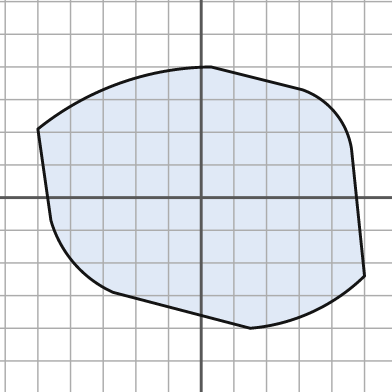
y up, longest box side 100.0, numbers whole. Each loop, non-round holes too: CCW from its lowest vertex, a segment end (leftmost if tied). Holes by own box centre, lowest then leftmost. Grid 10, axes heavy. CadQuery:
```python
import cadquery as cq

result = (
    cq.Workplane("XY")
    .moveTo(15.0, -40.0)
    .threePointArc((34.0, -35.0), (50.0, -24.0))
    .lineTo(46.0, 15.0)
    .threePointArc((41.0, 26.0), (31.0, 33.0))
    .lineTo(3.0, 40.0)
    .threePointArc((-25.0, 35.0), (-50.0, 21.0))
    .lineTo(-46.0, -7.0)
    .threePointArc((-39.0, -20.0), (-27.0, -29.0))
    .close()
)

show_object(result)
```